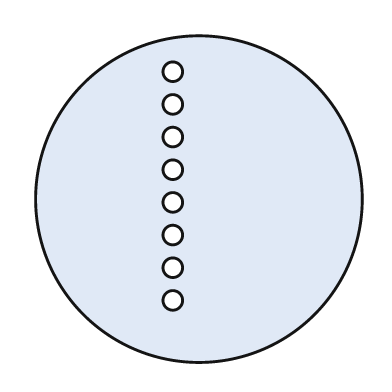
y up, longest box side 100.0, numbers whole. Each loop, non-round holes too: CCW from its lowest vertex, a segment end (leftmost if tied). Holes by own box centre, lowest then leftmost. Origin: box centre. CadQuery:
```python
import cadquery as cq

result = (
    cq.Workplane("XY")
    .moveTo(0.0, 0.0)
    .circle(50.0)
    .moveTo(-8.0, -31.0)
    .circle(3.0)
    .moveTo(-8.0, -21.0)
    .circle(3.0)
    .moveTo(-8.0, -11.0)
    .circle(3.0)
    .moveTo(-8.0, -1.0)
    .circle(3.0)
    .moveTo(-8.0, 9.0)
    .circle(3.0)
    .moveTo(-8.0, 19.0)
    .circle(3.0)
    .moveTo(-8.0, 29.0)
    .circle(3.0)
    .moveTo(-8.0, 39.0)
    .circle(3.0)
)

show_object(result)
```